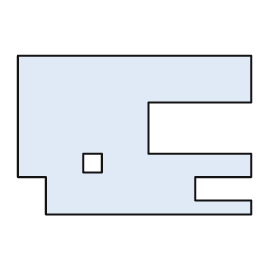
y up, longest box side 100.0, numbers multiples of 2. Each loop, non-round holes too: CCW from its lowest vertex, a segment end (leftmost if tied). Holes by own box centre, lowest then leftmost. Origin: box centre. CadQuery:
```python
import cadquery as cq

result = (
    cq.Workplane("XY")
    .moveTo(-38.0, -34.0)
    .lineTo(50.0, -34.0)
    .lineTo(50.0, -28.0)
    .lineTo(26.0, -28.0)
    .lineTo(26.0, -18.0)
    .lineTo(50.0, -18.0)
    .lineTo(50.0, -8.0)
    .lineTo(6.0, -8.0)
    .lineTo(6.0, 14.0)
    .lineTo(50.0, 14.0)
    .lineTo(50.0, 34.0)
    .lineTo(-50.0, 34.0)
    .lineTo(-50.0, -18.0)
    .lineTo(-38.0, -18.0)
    .close()
    .moveTo(-22.0, -16.0)
    .lineTo(-14.0, -16.0)
    .lineTo(-14.0, -8.0)
    .lineTo(-22.0, -8.0)
    .close()
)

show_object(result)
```